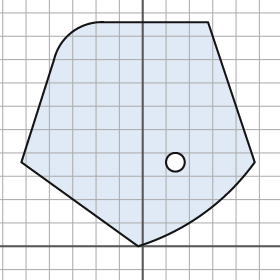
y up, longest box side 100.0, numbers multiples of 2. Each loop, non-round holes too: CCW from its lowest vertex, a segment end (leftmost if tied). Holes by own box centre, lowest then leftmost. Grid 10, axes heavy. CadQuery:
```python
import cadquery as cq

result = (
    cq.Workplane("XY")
    .moveTo(-2.0, 0.0)
    .threePointArc((26.0, 14.0), (48.0, 36.0))
    .lineTo(28.0, 96.0)
    .lineTo(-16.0, 96.0)
    .threePointArc((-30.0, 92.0), (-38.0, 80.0))
    .lineTo(-52.0, 36.0)
    .close()
    .moveTo(14.0, 36.0)
    .circle(4.0)
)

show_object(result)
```